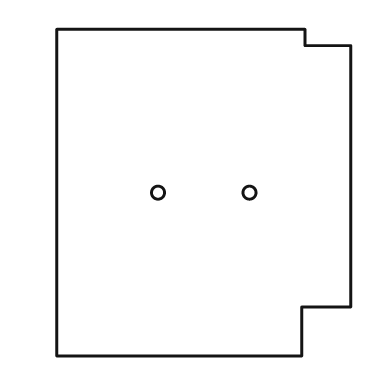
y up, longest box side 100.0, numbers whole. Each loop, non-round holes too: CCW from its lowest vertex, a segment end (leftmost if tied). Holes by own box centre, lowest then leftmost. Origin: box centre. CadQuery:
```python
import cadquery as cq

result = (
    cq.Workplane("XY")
    .moveTo(-45.0, -50.0)
    .lineTo(30.0, -50.0)
    .lineTo(30.0, -35.0)
    .lineTo(45.0, -35.0)
    .lineTo(45.0, 45.0)
    .lineTo(31.0, 45.0)
    .lineTo(31.0, 50.0)
    .lineTo(-45.0, 50.0)
    .close()
    .moveTo(-14.0, 0.0)
    .circle(2.0)
    .moveTo(14.0, 0.0)
    .circle(2.0)
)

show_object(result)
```